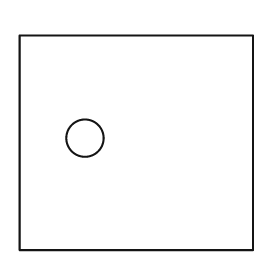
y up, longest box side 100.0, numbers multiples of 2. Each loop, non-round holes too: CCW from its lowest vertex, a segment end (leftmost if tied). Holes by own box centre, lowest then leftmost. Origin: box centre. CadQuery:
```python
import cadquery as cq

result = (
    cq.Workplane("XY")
    .moveTo(-50.0, -46.0)
    .lineTo(50.0, -46.0)
    .lineTo(50.0, 46.0)
    .lineTo(-50.0, 46.0)
    .close()
    .moveTo(-22.0, 2.0)
    .circle(8.0)
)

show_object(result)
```